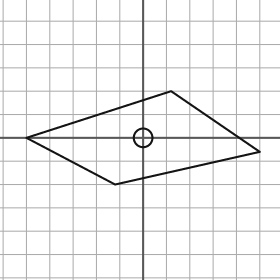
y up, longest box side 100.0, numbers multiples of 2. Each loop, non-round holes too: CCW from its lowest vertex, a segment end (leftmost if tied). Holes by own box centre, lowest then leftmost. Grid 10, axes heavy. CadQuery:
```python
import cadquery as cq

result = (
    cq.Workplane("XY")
    .moveTo(-12.0, -20.0)
    .lineTo(50.0, -6.0)
    .lineTo(12.0, 20.0)
    .lineTo(-50.0, 0.0)
    .close()
    .moveTo(0.0, 0.0)
    .circle(4.0)
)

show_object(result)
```